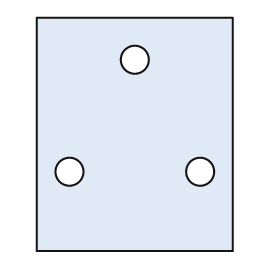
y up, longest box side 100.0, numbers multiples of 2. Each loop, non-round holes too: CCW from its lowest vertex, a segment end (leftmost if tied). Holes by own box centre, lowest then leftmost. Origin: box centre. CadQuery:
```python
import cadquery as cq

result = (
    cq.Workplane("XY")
    .moveTo(-42.0, -50.0)
    .lineTo(42.0, -50.0)
    .lineTo(42.0, 50.0)
    .lineTo(-42.0, 50.0)
    .close()
    .moveTo(-28.0, -16.0)
    .circle(6.0)
    .moveTo(28.0, -16.0)
    .circle(6.0)
    .moveTo(0.0, 32.0)
    .circle(6.0)
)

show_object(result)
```